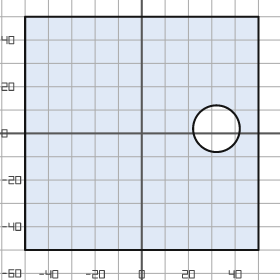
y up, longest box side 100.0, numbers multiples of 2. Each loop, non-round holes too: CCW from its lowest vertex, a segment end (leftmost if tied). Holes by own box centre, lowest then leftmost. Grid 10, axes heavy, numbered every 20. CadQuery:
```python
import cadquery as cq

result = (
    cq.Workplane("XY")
    .moveTo(-50.0, -50.0)
    .lineTo(50.0, -50.0)
    .lineTo(50.0, 50.0)
    .lineTo(-50.0, 50.0)
    .close()
    .moveTo(32.0, 2.0)
    .circle(10.0)
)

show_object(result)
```